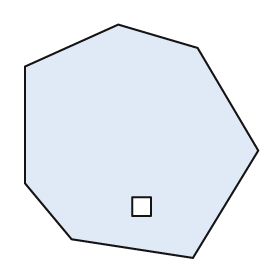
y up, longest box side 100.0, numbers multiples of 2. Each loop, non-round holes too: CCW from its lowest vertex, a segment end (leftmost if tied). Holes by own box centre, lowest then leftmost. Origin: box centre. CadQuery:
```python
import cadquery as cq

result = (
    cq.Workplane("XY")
    .moveTo(22.0, -50.0)
    .lineTo(50.0, -4.0)
    .lineTo(24.0, 40.0)
    .lineTo(-10.0, 50.0)
    .lineTo(-50.0, 32.0)
    .lineTo(-50.0, -18.0)
    .lineTo(-30.0, -42.0)
    .close()
    .moveTo(-4.0, -32.0)
    .lineTo(4.0, -32.0)
    .lineTo(4.0, -24.0)
    .lineTo(-4.0, -24.0)
    .close()
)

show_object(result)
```